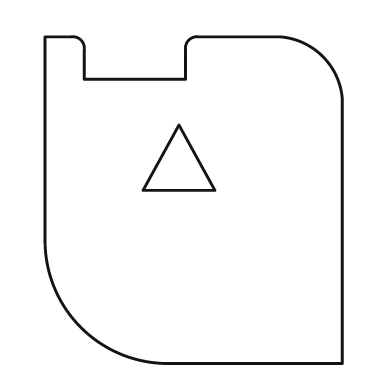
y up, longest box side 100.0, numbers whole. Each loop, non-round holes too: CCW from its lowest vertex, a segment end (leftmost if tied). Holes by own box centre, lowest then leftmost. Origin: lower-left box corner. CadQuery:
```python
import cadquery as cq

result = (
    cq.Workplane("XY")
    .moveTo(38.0, 0.0)
    .lineTo(91.0, 0.0)
    .lineTo(91.0, 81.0)
    .threePointArc((85.0, 94.0), (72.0, 100.0))
    .lineTo(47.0, 100.0)
    .threePointArc((44.0, 99.0), (43.0, 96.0))
    .lineTo(43.0, 87.0)
    .lineTo(12.0, 87.0)
    .lineTo(12.0, 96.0)
    .threePointArc((11.0, 99.0), (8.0, 100.0))
    .lineTo(0.0, 100.0)
    .lineTo(0.0, 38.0)
    .threePointArc((11.0, 11.0), (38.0, 0.0))
    .close()
    .moveTo(30.0, 53.0)
    .lineTo(52.0, 53.0)
    .lineTo(41.0, 73.0)
    .close()
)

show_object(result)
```